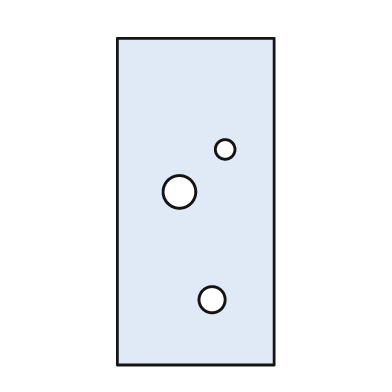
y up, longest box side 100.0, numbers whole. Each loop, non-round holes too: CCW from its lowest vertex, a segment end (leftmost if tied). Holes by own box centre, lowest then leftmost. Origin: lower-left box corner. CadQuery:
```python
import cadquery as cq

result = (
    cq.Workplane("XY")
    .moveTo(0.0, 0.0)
    .lineTo(48.0, 0.0)
    .lineTo(48.0, 100.0)
    .lineTo(0.0, 100.0)
    .close()
    .moveTo(29.0, 20.0)
    .circle(4.0)
    .moveTo(19.0, 53.0)
    .circle(5.0)
    .moveTo(33.0, 66.0)
    .circle(3.0)
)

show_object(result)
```